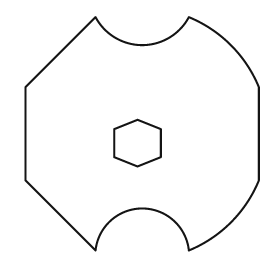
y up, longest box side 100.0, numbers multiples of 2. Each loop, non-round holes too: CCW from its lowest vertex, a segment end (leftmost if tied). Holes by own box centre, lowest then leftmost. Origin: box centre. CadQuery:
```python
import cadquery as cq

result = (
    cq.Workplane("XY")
    .moveTo(-20.0, -50.0)
    .threePointArc((0.0, -32.0), (20.0, -50.0))
    .threePointArc((38.0, -38.0), (50.0, -20.0))
    .lineTo(50.0, 20.0)
    .threePointArc((38.0, 38.0), (20.0, 50.0))
    .threePointArc((0.0, 38.0), (-20.0, 50.0))
    .lineTo(-50.0, 20.0)
    .lineTo(-50.0, -20.0)
    .close()
    .moveTo(-2.0, -14.0)
    .lineTo(8.0, -10.0)
    .lineTo(8.0, 2.0)
    .lineTo(-2.0, 6.0)
    .lineTo(-12.0, 2.0)
    .lineTo(-12.0, -10.0)
    .close()
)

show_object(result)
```